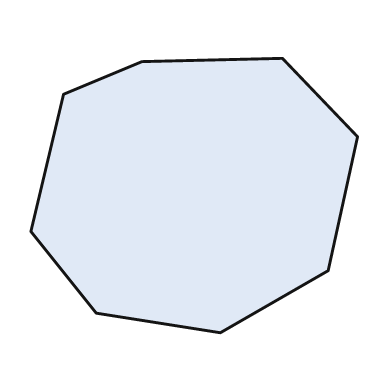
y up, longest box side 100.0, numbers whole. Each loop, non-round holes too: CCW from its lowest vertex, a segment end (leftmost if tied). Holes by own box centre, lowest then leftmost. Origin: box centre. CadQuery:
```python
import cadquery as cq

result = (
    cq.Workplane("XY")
    .moveTo(8.0, -42.0)
    .lineTo(41.0, -23.0)
    .lineTo(50.0, 18.0)
    .lineTo(27.0, 42.0)
    .lineTo(-16.0, 41.0)
    .lineTo(-40.0, 31.0)
    .lineTo(-50.0, -11.0)
    .lineTo(-30.0, -36.0)
    .close()
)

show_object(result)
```